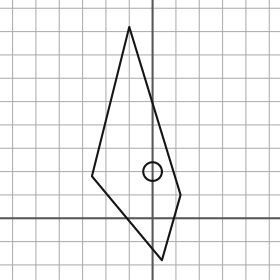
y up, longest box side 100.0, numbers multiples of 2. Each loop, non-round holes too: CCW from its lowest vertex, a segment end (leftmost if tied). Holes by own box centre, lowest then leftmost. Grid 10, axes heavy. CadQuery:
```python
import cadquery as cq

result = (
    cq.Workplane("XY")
    .moveTo(4.0, -18.0)
    .lineTo(12.0, 10.0)
    .lineTo(-10.0, 82.0)
    .lineTo(-26.0, 18.0)
    .close()
    .moveTo(0.0, 20.0)
    .circle(4.0)
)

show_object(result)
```